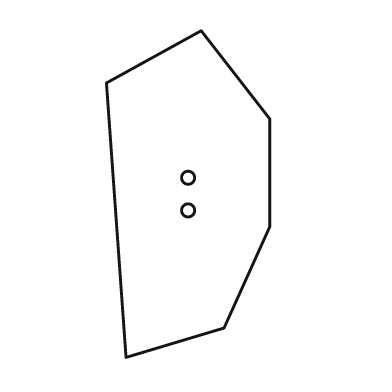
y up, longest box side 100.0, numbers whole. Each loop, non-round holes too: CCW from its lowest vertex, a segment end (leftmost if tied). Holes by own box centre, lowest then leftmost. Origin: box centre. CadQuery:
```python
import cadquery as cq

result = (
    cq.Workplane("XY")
    .moveTo(-19.0, -50.0)
    .lineTo(11.0, -41.0)
    .lineTo(25.0, -10.0)
    .lineTo(25.0, 23.0)
    .lineTo(4.0, 50.0)
    .lineTo(-25.0, 34.0)
    .close()
    .moveTo(0.0, -5.0)
    .circle(2.0)
    .moveTo(0.0, 5.0)
    .circle(2.0)
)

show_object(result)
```